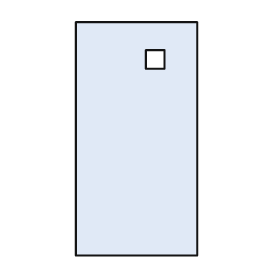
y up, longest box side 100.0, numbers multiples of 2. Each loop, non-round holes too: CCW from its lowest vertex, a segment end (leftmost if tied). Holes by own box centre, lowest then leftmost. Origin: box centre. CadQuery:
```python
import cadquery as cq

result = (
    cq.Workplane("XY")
    .moveTo(-26.0, -50.0)
    .lineTo(26.0, -50.0)
    .lineTo(26.0, 50.0)
    .lineTo(-26.0, 50.0)
    .close()
    .moveTo(4.0, 30.0)
    .lineTo(12.0, 30.0)
    .lineTo(12.0, 38.0)
    .lineTo(4.0, 38.0)
    .close()
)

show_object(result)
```